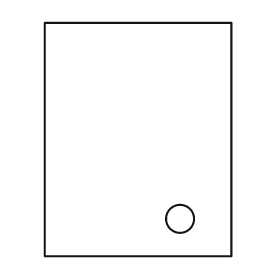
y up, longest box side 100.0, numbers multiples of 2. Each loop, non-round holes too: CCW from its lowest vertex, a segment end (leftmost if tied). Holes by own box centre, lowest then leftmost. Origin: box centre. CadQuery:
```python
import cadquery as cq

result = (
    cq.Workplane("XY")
    .moveTo(-40.0, -50.0)
    .lineTo(40.0, -50.0)
    .lineTo(40.0, 50.0)
    .lineTo(-40.0, 50.0)
    .close()
    .moveTo(18.0, -34.0)
    .circle(6.0)
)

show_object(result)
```